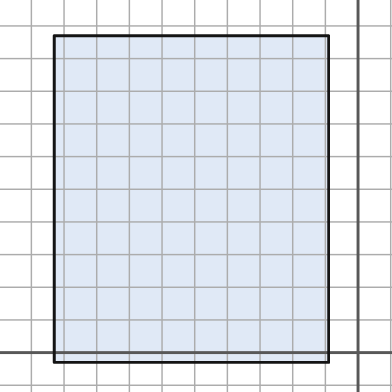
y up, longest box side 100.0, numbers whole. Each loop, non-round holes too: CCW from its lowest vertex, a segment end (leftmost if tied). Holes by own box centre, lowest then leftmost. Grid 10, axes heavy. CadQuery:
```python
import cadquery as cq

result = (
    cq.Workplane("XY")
    .moveTo(-93.0, -3.0)
    .lineTo(-9.0, -3.0)
    .lineTo(-9.0, 97.0)
    .lineTo(-93.0, 97.0)
    .close()
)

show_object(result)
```